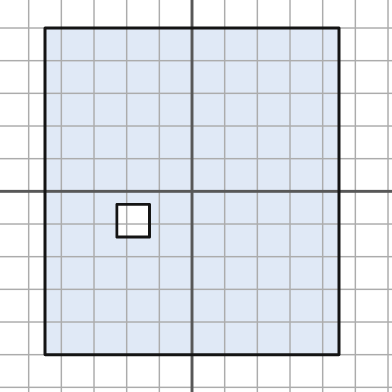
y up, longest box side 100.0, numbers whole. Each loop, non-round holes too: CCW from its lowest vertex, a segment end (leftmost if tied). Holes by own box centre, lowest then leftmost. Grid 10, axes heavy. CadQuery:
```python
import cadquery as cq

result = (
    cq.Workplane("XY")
    .moveTo(-45.0, -50.0)
    .lineTo(45.0, -50.0)
    .lineTo(45.0, 50.0)
    .lineTo(-45.0, 50.0)
    .close()
    .moveTo(-23.0, -14.0)
    .lineTo(-13.0, -14.0)
    .lineTo(-13.0, -4.0)
    .lineTo(-23.0, -4.0)
    .close()
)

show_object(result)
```